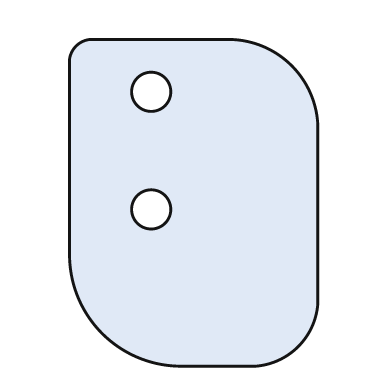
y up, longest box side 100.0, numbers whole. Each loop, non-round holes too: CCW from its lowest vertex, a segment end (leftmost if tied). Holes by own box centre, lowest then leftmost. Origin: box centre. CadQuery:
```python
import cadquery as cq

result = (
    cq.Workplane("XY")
    .moveTo(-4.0, -50.0)
    .lineTo(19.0, -50.0)
    .threePointArc((32.0, -44.0), (38.0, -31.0))
    .lineTo(38.0, 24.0)
    .threePointArc((30.0, 42.0), (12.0, 50.0))
    .lineTo(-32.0, 50.0)
    .threePointArc((-36.0, 48.0), (-38.0, 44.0))
    .lineTo(-38.0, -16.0)
    .threePointArc((-28.0, -40.0), (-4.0, -50.0))
    .close()
    .moveTo(-13.0, -2.0)
    .circle(6.0)
    .moveTo(-13.0, 34.0)
    .circle(6.0)
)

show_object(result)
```